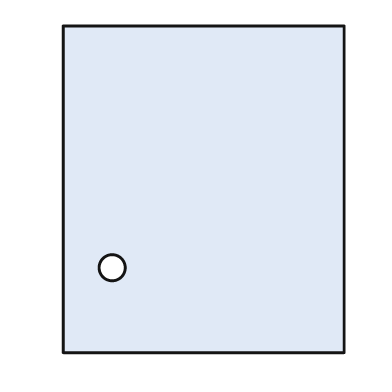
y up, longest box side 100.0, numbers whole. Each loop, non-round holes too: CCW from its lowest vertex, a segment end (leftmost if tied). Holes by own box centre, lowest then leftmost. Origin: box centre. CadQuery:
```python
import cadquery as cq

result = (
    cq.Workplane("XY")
    .moveTo(-43.0, -50.0)
    .lineTo(43.0, -50.0)
    .lineTo(43.0, 50.0)
    .lineTo(-43.0, 50.0)
    .close()
    .moveTo(-28.0, -24.0)
    .circle(4.0)
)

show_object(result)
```